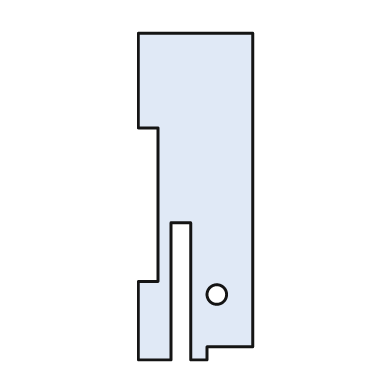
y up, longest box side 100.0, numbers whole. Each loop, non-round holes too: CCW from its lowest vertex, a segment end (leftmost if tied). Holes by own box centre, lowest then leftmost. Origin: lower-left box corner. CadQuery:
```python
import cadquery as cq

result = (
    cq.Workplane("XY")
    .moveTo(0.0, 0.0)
    .lineTo(10.0, 0.0)
    .lineTo(10.0, 42.0)
    .lineTo(16.0, 42.0)
    .lineTo(16.0, 0.0)
    .lineTo(21.0, 0.0)
    .lineTo(21.0, 4.0)
    .lineTo(35.0, 4.0)
    .lineTo(35.0, 100.0)
    .lineTo(0.0, 100.0)
    .lineTo(0.0, 71.0)
    .lineTo(6.0, 71.0)
    .lineTo(6.0, 24.0)
    .lineTo(0.0, 24.0)
    .close()
    .moveTo(24.0, 20.0)
    .circle(3.0)
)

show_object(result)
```